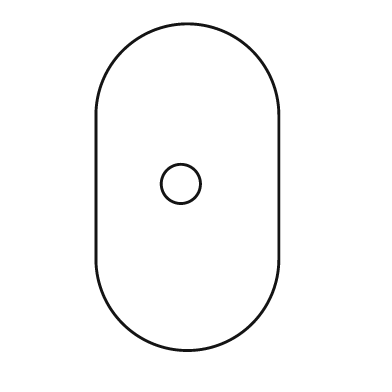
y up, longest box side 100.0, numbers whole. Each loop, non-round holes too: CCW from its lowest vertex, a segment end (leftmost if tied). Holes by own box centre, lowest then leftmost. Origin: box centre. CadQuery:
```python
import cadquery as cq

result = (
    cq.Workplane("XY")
    .moveTo(-28.0, -22.0)
    .threePointArc((0.0, -50.0), (28.0, -22.0))
    .lineTo(28.0, 22.0)
    .threePointArc((0.0, 50.0), (-28.0, 22.0))
    .close()
    .moveTo(-2.0, 1.0)
    .circle(6.0)
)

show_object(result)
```